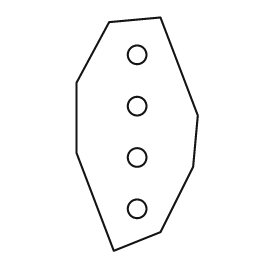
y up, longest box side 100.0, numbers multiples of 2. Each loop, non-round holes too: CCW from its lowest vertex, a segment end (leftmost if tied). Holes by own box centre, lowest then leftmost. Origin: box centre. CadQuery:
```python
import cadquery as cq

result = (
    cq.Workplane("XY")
    .moveTo(-10.0, -50.0)
    .lineTo(10.0, -42.0)
    .lineTo(24.0, -14.0)
    .lineTo(26.0, 8.0)
    .lineTo(10.0, 50.0)
    .lineTo(-12.0, 48.0)
    .lineTo(-26.0, 22.0)
    .lineTo(-26.0, -8.0)
    .close()
    .moveTo(0.0, -32.0)
    .circle(4.0)
    .moveTo(0.0, -10.0)
    .circle(4.0)
    .moveTo(0.0, 12.0)
    .circle(4.0)
    .moveTo(0.0, 34.0)
    .circle(4.0)
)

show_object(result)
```